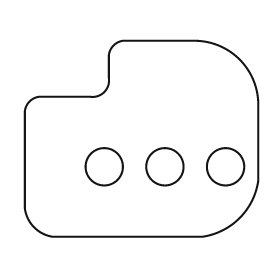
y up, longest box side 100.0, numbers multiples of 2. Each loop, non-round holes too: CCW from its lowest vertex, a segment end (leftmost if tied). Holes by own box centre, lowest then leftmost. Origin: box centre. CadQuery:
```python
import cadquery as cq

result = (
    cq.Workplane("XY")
    .moveTo(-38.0, -42.0)
    .lineTo(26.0, -42.0)
    .threePointArc((42.0, -34.0), (50.0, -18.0))
    .lineTo(50.0, 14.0)
    .threePointArc((42.0, 34.0), (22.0, 42.0))
    .lineTo(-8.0, 42.0)
    .threePointArc((-12.0, 40.0), (-14.0, 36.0))
    .lineTo(-14.0, 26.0)
    .threePointArc((-16.0, 20.0), (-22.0, 18.0))
    .lineTo(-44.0, 18.0)
    .threePointArc((-48.0, 16.0), (-50.0, 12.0))
    .lineTo(-50.0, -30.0)
    .threePointArc((-46.0, -38.0), (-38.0, -42.0))
    .close()
    .moveTo(-16.0, -12.0)
    .circle(8.0)
    .moveTo(10.0, -12.0)
    .circle(8.0)
    .moveTo(36.0, -12.0)
    .circle(8.0)
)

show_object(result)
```